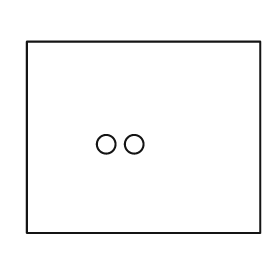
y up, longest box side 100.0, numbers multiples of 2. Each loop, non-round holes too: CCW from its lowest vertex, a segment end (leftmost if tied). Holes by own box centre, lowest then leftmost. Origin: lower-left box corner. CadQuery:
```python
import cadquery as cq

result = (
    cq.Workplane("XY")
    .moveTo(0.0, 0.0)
    .lineTo(100.0, 0.0)
    .lineTo(100.0, 82.0)
    .lineTo(0.0, 82.0)
    .close()
    .moveTo(34.0, 38.0)
    .circle(4.0)
    .moveTo(46.0, 38.0)
    .circle(4.0)
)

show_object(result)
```